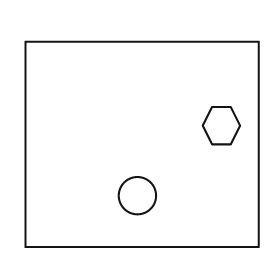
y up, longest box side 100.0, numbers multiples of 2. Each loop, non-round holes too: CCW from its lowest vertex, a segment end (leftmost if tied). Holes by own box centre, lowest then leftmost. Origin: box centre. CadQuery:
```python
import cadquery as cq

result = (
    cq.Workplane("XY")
    .moveTo(-50.0, -44.0)
    .lineTo(50.0, -44.0)
    .lineTo(50.0, 44.0)
    .lineTo(-50.0, 44.0)
    .close()
    .moveTo(-2.0, -22.0)
    .circle(8.0)
    .moveTo(30.0, 0.0)
    .lineTo(38.0, 0.0)
    .lineTo(42.0, 8.0)
    .lineTo(38.0, 16.0)
    .lineTo(30.0, 16.0)
    .lineTo(26.0, 8.0)
    .close()
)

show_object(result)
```